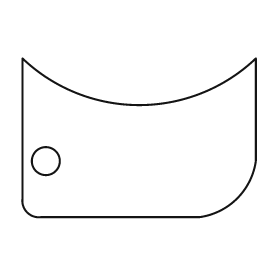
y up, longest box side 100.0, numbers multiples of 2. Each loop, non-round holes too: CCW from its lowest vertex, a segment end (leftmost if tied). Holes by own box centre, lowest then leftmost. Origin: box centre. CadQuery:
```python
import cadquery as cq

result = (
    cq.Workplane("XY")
    .moveTo(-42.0, -34.0)
    .lineTo(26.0, -34.0)
    .threePointArc((42.0, -26.0), (50.0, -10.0))
    .lineTo(50.0, 34.0)
    .threePointArc((0.0, 14.0), (-50.0, 34.0))
    .lineTo(-50.0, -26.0)
    .threePointArc((-48.0, -32.0), (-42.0, -34.0))
    .close()
    .moveTo(-40.0, -10.0)
    .circle(6.0)
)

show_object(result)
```